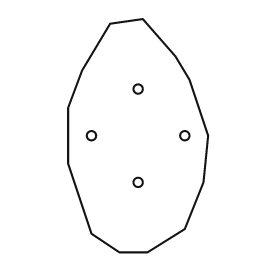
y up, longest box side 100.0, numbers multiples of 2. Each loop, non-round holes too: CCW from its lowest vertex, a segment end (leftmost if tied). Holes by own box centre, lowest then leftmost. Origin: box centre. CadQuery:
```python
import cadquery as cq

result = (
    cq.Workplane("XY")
    .moveTo(-8.0, -50.0)
    .lineTo(4.0, -50.0)
    .lineTo(20.0, -40.0)
    .lineTo(28.0, -20.0)
    .lineTo(30.0, 0.0)
    .lineTo(22.0, 24.0)
    .lineTo(16.0, 34.0)
    .lineTo(2.0, 50.0)
    .lineTo(-12.0, 48.0)
    .lineTo(-24.0, 28.0)
    .lineTo(-30.0, 12.0)
    .lineTo(-30.0, -12.0)
    .lineTo(-20.0, -42.0)
    .close()
    .moveTo(0.0, -20.0)
    .circle(2.0)
    .moveTo(-20.0, 0.0)
    .circle(2.0)
    .moveTo(20.0, 0.0)
    .circle(2.0)
    .moveTo(0.0, 20.0)
    .circle(2.0)
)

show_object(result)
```